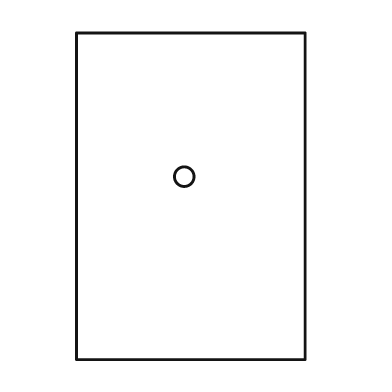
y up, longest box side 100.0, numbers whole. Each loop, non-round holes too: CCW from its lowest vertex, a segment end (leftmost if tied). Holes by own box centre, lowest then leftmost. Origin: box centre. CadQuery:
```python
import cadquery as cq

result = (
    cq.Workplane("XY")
    .moveTo(-35.0, -50.0)
    .lineTo(35.0, -50.0)
    .lineTo(35.0, 50.0)
    .lineTo(-35.0, 50.0)
    .close()
    .moveTo(-2.0, 6.0)
    .circle(3.0)
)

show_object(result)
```